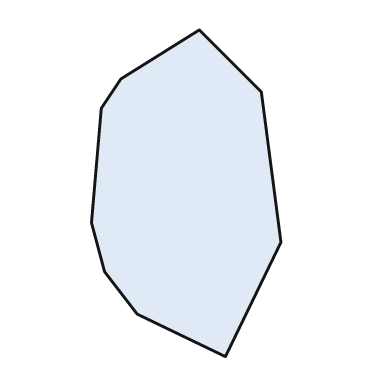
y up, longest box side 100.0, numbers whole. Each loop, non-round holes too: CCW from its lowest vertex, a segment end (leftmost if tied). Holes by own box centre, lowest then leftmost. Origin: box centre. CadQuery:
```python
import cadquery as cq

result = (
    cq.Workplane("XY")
    .moveTo(12.0, -50.0)
    .lineTo(29.0, -15.0)
    .lineTo(23.0, 31.0)
    .lineTo(4.0, 50.0)
    .lineTo(-20.0, 35.0)
    .lineTo(-26.0, 26.0)
    .lineTo(-29.0, -9.0)
    .lineTo(-25.0, -24.0)
    .lineTo(-15.0, -37.0)
    .close()
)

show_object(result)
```